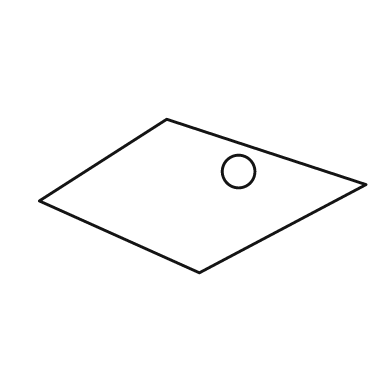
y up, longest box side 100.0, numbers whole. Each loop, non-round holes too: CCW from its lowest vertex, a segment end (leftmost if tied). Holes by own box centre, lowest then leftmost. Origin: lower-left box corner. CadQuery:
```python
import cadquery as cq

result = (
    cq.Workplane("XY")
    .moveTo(49.0, 0.0)
    .lineTo(100.0, 27.0)
    .lineTo(39.0, 47.0)
    .lineTo(0.0, 22.0)
    .close()
    .moveTo(61.0, 31.0)
    .circle(5.0)
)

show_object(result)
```